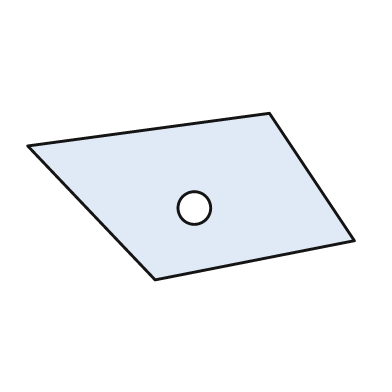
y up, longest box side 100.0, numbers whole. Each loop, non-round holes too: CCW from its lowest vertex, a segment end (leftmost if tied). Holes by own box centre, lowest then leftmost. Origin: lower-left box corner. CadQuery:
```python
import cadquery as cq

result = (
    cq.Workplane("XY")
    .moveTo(39.0, 0.0)
    .lineTo(100.0, 12.0)
    .lineTo(74.0, 51.0)
    .lineTo(0.0, 41.0)
    .close()
    .moveTo(51.0, 22.0)
    .circle(5.0)
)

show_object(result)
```